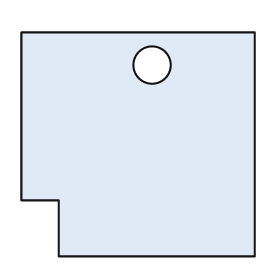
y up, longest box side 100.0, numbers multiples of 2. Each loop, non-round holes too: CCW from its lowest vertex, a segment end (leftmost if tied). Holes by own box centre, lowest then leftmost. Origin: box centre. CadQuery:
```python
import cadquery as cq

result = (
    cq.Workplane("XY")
    .moveTo(-34.0, -48.0)
    .lineTo(50.0, -48.0)
    .lineTo(50.0, 48.0)
    .lineTo(-50.0, 48.0)
    .lineTo(-50.0, -24.0)
    .lineTo(-34.0, -24.0)
    .close()
    .moveTo(6.0, 34.0)
    .circle(8.0)
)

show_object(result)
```